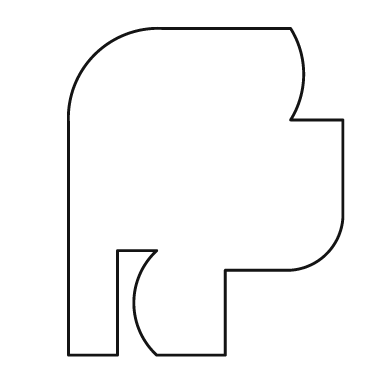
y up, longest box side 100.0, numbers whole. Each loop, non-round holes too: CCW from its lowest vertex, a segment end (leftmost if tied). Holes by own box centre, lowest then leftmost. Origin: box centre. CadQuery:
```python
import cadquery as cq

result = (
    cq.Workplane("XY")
    .moveTo(-42.0, -50.0)
    .lineTo(-27.0, -50.0)
    .lineTo(-27.0, -18.0)
    .lineTo(-15.0, -18.0)
    .threePointArc((-22.0, -34.0), (-15.0, -50.0))
    .lineTo(6.0, -50.0)
    .lineTo(6.0, -24.0)
    .lineTo(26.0, -24.0)
    .threePointArc((37.0, -19.0), (42.0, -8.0))
    .lineTo(42.0, 22.0)
    .lineTo(26.0, 22.0)
    .threePointArc((30.0, 36.0), (26.0, 50.0))
    .lineTo(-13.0, 50.0)
    .threePointArc((-34.0, 42.0), (-42.0, 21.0))
    .close()
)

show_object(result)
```